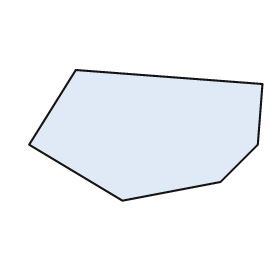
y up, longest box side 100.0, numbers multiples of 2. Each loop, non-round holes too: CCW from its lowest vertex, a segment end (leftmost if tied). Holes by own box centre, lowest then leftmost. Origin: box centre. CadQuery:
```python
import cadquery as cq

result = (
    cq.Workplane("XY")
    .moveTo(-10.0, -28.0)
    .lineTo(32.0, -20.0)
    .lineTo(48.0, -4.0)
    .lineTo(50.0, 22.0)
    .lineTo(-30.0, 28.0)
    .lineTo(-50.0, -4.0)
    .close()
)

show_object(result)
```